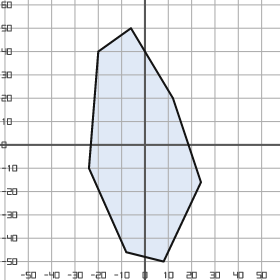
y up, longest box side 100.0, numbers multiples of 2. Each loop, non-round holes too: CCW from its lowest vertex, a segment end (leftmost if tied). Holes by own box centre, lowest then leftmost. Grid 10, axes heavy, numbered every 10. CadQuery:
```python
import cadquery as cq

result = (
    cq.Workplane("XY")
    .moveTo(8.0, -50.0)
    .lineTo(24.0, -16.0)
    .lineTo(12.0, 20.0)
    .lineTo(-6.0, 50.0)
    .lineTo(-20.0, 40.0)
    .lineTo(-24.0, -10.0)
    .lineTo(-8.0, -46.0)
    .close()
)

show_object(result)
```